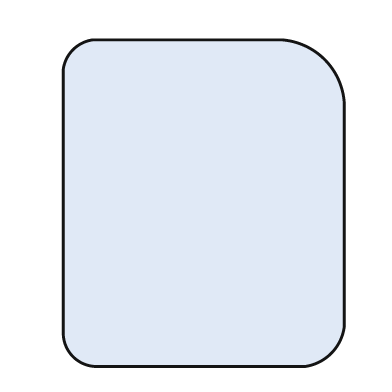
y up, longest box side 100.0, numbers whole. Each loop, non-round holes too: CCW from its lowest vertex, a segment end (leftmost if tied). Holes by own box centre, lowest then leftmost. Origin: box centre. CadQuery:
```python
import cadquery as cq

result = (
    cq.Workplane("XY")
    .moveTo(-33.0, -50.0)
    .lineTo(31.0, -50.0)
    .threePointArc((39.0, -46.0), (43.0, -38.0))
    .lineTo(43.0, 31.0)
    .threePointArc((37.0, 44.0), (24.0, 50.0))
    .lineTo(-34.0, 50.0)
    .threePointArc((-40.0, 47.0), (-43.0, 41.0))
    .lineTo(-43.0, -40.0)
    .threePointArc((-40.0, -47.0), (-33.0, -50.0))
    .close()
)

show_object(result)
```